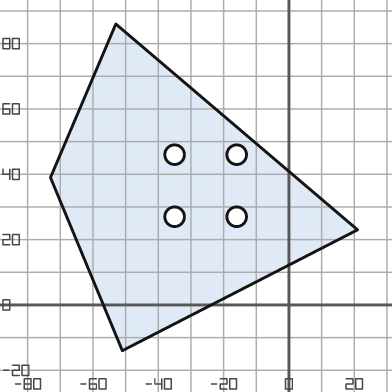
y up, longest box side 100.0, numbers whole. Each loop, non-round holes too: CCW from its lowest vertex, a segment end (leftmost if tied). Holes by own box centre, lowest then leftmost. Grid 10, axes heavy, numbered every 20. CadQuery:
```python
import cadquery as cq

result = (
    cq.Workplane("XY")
    .moveTo(-51.0, -14.0)
    .lineTo(21.0, 23.0)
    .lineTo(-53.0, 86.0)
    .lineTo(-73.0, 39.0)
    .close()
    .moveTo(-35.0, 27.0)
    .circle(3.0)
    .moveTo(-16.0, 27.0)
    .circle(3.0)
    .moveTo(-35.0, 46.0)
    .circle(3.0)
    .moveTo(-16.0, 46.0)
    .circle(3.0)
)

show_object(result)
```